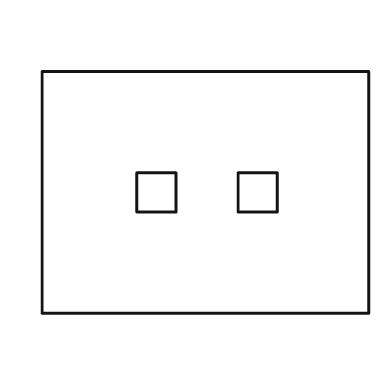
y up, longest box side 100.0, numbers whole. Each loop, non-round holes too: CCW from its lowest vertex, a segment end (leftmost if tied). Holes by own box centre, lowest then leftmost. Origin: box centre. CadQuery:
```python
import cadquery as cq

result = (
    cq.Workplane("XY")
    .moveTo(-50.0, -37.0)
    .lineTo(50.0, -37.0)
    .lineTo(50.0, 37.0)
    .lineTo(-50.0, 37.0)
    .close()
    .moveTo(-21.0, -6.0)
    .lineTo(-9.0, -6.0)
    .lineTo(-9.0, 6.0)
    .lineTo(-21.0, 6.0)
    .close()
    .moveTo(10.0, -6.0)
    .lineTo(22.0, -6.0)
    .lineTo(22.0, 6.0)
    .lineTo(10.0, 6.0)
    .close()
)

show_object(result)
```